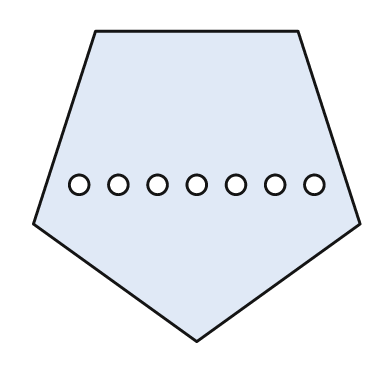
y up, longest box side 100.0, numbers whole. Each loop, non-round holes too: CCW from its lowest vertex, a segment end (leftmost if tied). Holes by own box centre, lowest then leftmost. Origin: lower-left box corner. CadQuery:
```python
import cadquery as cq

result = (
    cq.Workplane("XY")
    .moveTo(50.0, 0.0)
    .lineTo(100.0, 36.0)
    .lineTo(81.0, 95.0)
    .lineTo(19.0, 95.0)
    .lineTo(0.0, 36.0)
    .close()
    .moveTo(14.0, 48.0)
    .circle(3.0)
    .moveTo(26.0, 48.0)
    .circle(3.0)
    .moveTo(38.0, 48.0)
    .circle(3.0)
    .moveTo(50.0, 48.0)
    .circle(3.0)
    .moveTo(62.0, 48.0)
    .circle(3.0)
    .moveTo(74.0, 48.0)
    .circle(3.0)
    .moveTo(86.0, 48.0)
    .circle(3.0)
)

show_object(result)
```